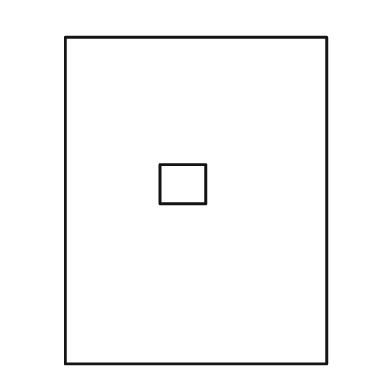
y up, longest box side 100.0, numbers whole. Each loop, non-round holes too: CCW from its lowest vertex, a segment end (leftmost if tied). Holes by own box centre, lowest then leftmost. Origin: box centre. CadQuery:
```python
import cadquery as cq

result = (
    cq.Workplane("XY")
    .moveTo(-40.0, -50.0)
    .lineTo(40.0, -50.0)
    .lineTo(40.0, 50.0)
    .lineTo(-40.0, 50.0)
    .close()
    .moveTo(-11.0, -1.0)
    .lineTo(3.0, -1.0)
    .lineTo(3.0, 11.0)
    .lineTo(-11.0, 11.0)
    .close()
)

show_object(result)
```